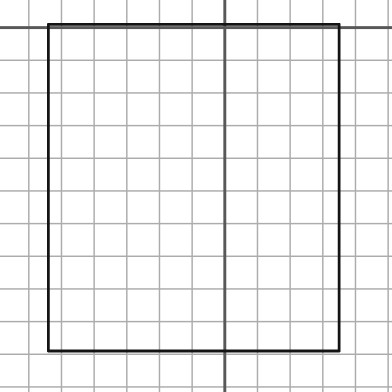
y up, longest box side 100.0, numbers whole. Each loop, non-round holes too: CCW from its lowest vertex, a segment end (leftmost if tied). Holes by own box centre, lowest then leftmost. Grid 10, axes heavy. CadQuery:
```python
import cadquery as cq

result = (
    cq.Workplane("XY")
    .moveTo(-54.0, -99.0)
    .lineTo(35.0, -99.0)
    .lineTo(35.0, 1.0)
    .lineTo(-54.0, 1.0)
    .close()
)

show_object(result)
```